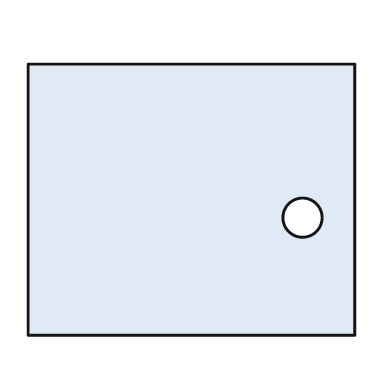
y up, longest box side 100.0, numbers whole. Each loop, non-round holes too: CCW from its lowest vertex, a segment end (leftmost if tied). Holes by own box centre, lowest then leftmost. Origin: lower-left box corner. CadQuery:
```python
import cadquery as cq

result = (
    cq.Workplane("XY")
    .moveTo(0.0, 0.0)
    .lineTo(100.0, 0.0)
    .lineTo(100.0, 83.0)
    .lineTo(0.0, 83.0)
    .close()
    .moveTo(84.0, 36.0)
    .circle(6.0)
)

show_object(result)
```